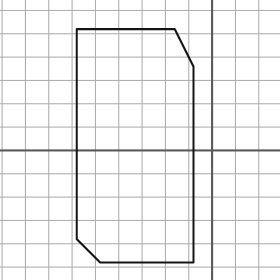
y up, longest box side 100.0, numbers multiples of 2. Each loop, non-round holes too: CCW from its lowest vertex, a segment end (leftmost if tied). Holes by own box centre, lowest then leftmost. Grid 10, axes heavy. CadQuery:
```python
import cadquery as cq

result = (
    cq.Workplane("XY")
    .moveTo(-48.0, -48.0)
    .lineTo(-8.0, -48.0)
    .lineTo(-8.0, 36.0)
    .lineTo(-16.0, 52.0)
    .lineTo(-58.0, 52.0)
    .lineTo(-58.0, -38.0)
    .close()
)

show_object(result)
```